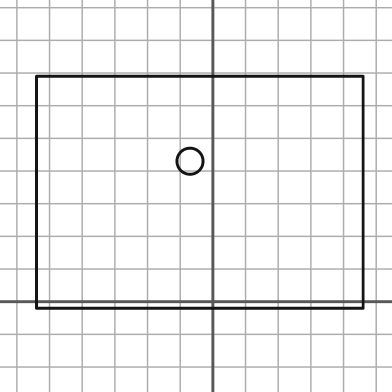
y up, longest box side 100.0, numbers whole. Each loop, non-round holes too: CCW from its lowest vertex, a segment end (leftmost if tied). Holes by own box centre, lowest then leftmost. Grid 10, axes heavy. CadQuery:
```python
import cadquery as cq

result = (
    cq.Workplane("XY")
    .moveTo(-54.0, -2.0)
    .lineTo(46.0, -2.0)
    .lineTo(46.0, 69.0)
    .lineTo(-54.0, 69.0)
    .close()
    .moveTo(-7.0, 43.0)
    .circle(4.0)
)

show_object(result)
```